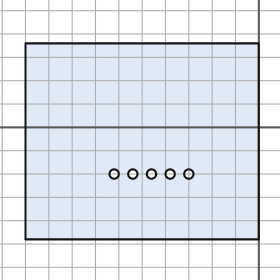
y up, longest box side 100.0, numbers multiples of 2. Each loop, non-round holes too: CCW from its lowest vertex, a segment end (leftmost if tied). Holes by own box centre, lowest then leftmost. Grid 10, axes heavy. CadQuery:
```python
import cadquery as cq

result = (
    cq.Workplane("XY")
    .moveTo(-100.0, -48.0)
    .lineTo(0.0, -48.0)
    .lineTo(0.0, 36.0)
    .lineTo(-100.0, 36.0)
    .close()
    .moveTo(-62.0, -20.0)
    .circle(2.0)
    .moveTo(-54.0, -20.0)
    .circle(2.0)
    .moveTo(-46.0, -20.0)
    .circle(2.0)
    .moveTo(-38.0, -20.0)
    .circle(2.0)
    .moveTo(-30.0, -20.0)
    .circle(2.0)
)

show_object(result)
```